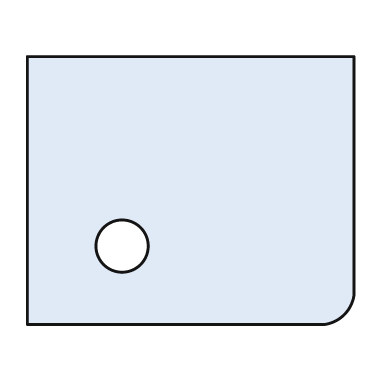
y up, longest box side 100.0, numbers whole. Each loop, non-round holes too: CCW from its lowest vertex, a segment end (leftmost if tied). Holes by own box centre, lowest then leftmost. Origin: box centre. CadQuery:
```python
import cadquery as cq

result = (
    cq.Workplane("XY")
    .moveTo(-50.0, -41.0)
    .lineTo(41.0, -41.0)
    .threePointArc((47.0, -38.0), (50.0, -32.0))
    .lineTo(50.0, 41.0)
    .lineTo(-50.0, 41.0)
    .close()
    .moveTo(-21.0, -17.0)
    .circle(8.0)
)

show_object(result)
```